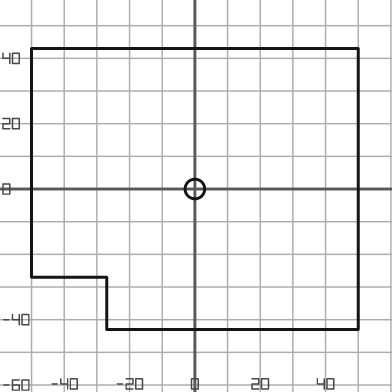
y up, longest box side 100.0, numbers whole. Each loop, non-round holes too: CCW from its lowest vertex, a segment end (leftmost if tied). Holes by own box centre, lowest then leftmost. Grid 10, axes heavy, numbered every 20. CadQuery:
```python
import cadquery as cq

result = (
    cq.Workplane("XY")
    .moveTo(-27.0, -43.0)
    .lineTo(50.0, -43.0)
    .lineTo(50.0, 43.0)
    .lineTo(-50.0, 43.0)
    .lineTo(-50.0, -27.0)
    .lineTo(-27.0, -27.0)
    .close()
    .moveTo(0.0, 0.0)
    .circle(3.0)
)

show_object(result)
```